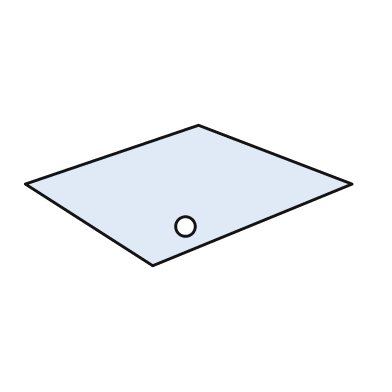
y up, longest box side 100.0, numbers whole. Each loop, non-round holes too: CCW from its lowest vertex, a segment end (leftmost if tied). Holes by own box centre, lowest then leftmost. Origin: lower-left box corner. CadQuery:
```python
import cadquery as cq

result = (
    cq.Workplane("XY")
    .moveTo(39.0, 0.0)
    .lineTo(100.0, 25.0)
    .lineTo(53.0, 43.0)
    .lineTo(0.0, 25.0)
    .close()
    .moveTo(49.0, 12.0)
    .circle(3.0)
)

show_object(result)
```